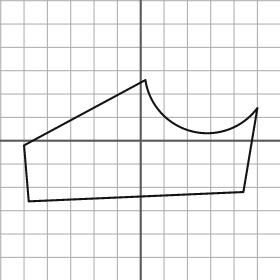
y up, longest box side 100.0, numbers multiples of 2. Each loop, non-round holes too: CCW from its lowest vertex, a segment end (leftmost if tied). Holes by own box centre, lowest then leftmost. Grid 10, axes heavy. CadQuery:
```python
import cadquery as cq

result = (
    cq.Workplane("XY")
    .moveTo(-48.0, -26.0)
    .lineTo(44.0, -22.0)
    .lineTo(50.0, 14.0)
    .threePointArc((22.0, 4.0), (2.0, 26.0))
    .lineTo(-50.0, -2.0)
    .close()
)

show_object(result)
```